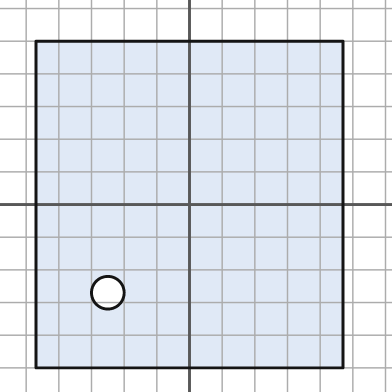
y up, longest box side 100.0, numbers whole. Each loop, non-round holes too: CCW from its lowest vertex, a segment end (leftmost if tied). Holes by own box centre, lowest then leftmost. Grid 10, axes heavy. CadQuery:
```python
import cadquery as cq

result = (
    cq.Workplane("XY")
    .moveTo(-47.0, -50.0)
    .lineTo(47.0, -50.0)
    .lineTo(47.0, 50.0)
    .lineTo(-47.0, 50.0)
    .close()
    .moveTo(-25.0, -27.0)
    .circle(5.0)
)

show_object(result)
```